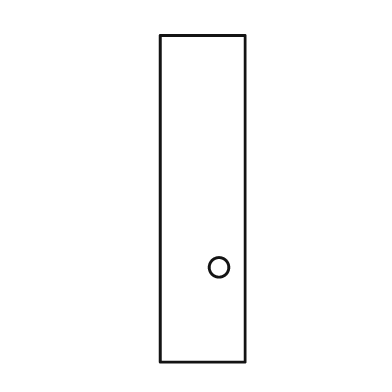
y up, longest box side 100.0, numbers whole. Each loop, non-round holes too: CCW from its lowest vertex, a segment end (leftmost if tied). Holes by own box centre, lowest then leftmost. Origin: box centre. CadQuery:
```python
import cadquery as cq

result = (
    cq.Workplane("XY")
    .moveTo(-13.0, -50.0)
    .lineTo(13.0, -50.0)
    .lineTo(13.0, 50.0)
    .lineTo(-13.0, 50.0)
    .close()
    .moveTo(5.0, -21.0)
    .circle(3.0)
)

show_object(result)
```